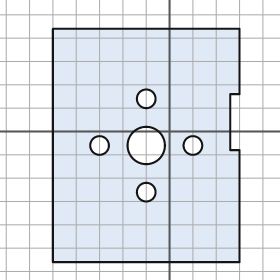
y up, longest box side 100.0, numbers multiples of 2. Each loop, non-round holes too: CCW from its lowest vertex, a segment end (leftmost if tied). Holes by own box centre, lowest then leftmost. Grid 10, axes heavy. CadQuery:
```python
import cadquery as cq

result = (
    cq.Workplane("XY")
    .moveTo(-50.0, -56.0)
    .lineTo(30.0, -56.0)
    .lineTo(30.0, -8.0)
    .lineTo(26.0, -8.0)
    .lineTo(26.0, 16.0)
    .lineTo(30.0, 16.0)
    .lineTo(30.0, 44.0)
    .lineTo(-50.0, 44.0)
    .close()
    .moveTo(-10.0, -26.0)
    .circle(4.0)
    .moveTo(-30.0, -6.0)
    .circle(4.0)
    .moveTo(-10.0, -6.0)
    .circle(8.0)
    .moveTo(10.0, -6.0)
    .circle(4.0)
    .moveTo(-10.0, 14.0)
    .circle(4.0)
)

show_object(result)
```